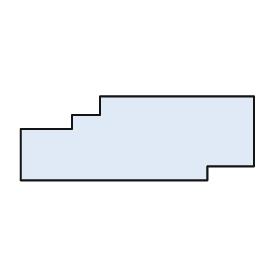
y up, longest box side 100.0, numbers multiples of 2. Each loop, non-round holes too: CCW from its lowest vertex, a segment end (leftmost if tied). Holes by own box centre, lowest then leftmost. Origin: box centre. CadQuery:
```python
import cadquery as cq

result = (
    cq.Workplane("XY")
    .moveTo(-50.0, -18.0)
    .lineTo(30.0, -18.0)
    .lineTo(30.0, -12.0)
    .lineTo(50.0, -12.0)
    .lineTo(50.0, 18.0)
    .lineTo(-16.0, 18.0)
    .lineTo(-16.0, 10.0)
    .lineTo(-28.0, 10.0)
    .lineTo(-28.0, 4.0)
    .lineTo(-50.0, 4.0)
    .close()
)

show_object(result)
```